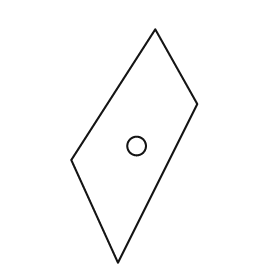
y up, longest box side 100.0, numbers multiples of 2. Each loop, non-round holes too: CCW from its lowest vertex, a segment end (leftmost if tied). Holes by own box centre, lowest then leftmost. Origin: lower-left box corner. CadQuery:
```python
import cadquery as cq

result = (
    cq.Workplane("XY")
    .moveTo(20.0, 0.0)
    .lineTo(54.0, 68.0)
    .lineTo(36.0, 100.0)
    .lineTo(0.0, 44.0)
    .close()
    .moveTo(28.0, 50.0)
    .circle(4.0)
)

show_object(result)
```